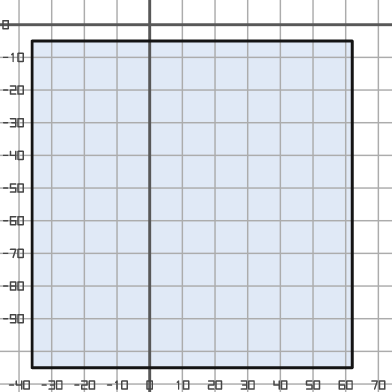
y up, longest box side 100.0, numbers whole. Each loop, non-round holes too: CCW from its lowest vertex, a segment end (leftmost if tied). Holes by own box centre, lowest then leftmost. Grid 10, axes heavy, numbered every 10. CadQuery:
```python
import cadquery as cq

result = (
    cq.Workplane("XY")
    .moveTo(-36.0, -105.0)
    .lineTo(62.0, -105.0)
    .lineTo(62.0, -5.0)
    .lineTo(-36.0, -5.0)
    .close()
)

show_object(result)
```